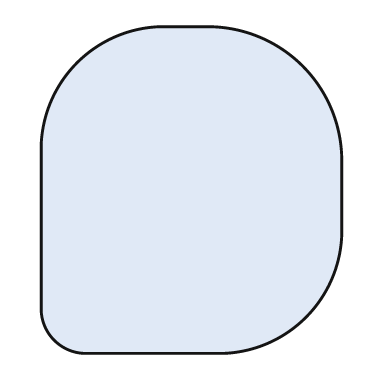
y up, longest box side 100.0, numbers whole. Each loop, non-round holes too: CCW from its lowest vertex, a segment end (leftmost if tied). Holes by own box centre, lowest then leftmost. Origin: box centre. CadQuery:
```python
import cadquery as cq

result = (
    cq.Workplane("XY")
    .moveTo(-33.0, -50.0)
    .lineTo(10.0, -50.0)
    .threePointArc((35.0, -39.0), (46.0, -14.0))
    .lineTo(46.0, 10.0)
    .threePointArc((34.0, 38.0), (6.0, 50.0))
    .lineTo(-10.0, 50.0)
    .threePointArc((-35.0, 39.0), (-46.0, 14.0))
    .lineTo(-46.0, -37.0)
    .threePointArc((-42.0, -46.0), (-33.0, -50.0))
    .close()
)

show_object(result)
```